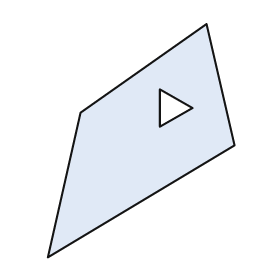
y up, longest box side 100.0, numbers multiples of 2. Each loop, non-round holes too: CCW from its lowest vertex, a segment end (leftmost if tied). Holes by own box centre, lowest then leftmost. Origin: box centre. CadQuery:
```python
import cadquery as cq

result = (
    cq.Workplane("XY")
    .moveTo(-40.0, -50.0)
    .lineTo(40.0, -2.0)
    .lineTo(28.0, 50.0)
    .lineTo(-26.0, 12.0)
    .close()
    .moveTo(8.0, 6.0)
    .lineTo(22.0, 14.0)
    .lineTo(8.0, 22.0)
    .close()
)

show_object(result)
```